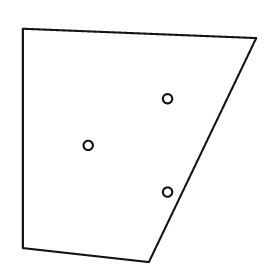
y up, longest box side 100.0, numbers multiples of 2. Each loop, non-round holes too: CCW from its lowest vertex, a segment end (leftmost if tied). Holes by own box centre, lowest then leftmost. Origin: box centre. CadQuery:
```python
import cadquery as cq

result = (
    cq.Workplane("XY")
    .moveTo(4.0, -50.0)
    .lineTo(50.0, 46.0)
    .lineTo(-50.0, 50.0)
    .lineTo(-50.0, -44.0)
    .close()
    .moveTo(12.0, -20.0)
    .circle(2.0)
    .moveTo(-22.0, 0.0)
    .circle(2.0)
    .moveTo(12.0, 20.0)
    .circle(2.0)
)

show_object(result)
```